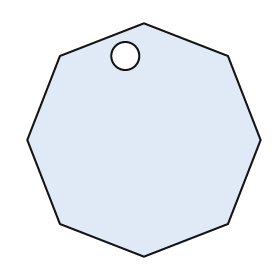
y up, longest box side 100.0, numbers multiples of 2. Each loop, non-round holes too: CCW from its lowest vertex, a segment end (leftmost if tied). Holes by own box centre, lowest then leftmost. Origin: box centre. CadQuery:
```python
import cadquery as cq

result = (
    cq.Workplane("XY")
    .moveTo(0.0, -50.0)
    .lineTo(36.0, -36.0)
    .lineTo(50.0, 0.0)
    .lineTo(36.0, 36.0)
    .lineTo(0.0, 50.0)
    .lineTo(-36.0, 36.0)
    .lineTo(-50.0, 0.0)
    .lineTo(-36.0, -36.0)
    .close()
    .moveTo(-8.0, 36.0)
    .circle(6.0)
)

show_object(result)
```